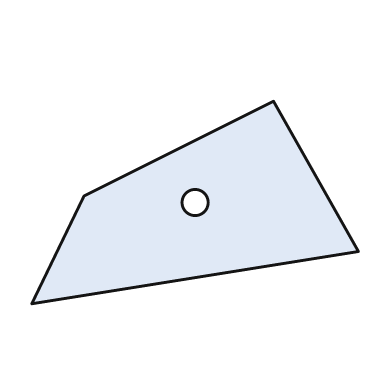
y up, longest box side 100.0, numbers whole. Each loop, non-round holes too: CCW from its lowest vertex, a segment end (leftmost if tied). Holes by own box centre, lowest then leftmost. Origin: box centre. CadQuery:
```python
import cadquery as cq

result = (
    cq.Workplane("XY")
    .moveTo(-50.0, -31.0)
    .lineTo(50.0, -15.0)
    .lineTo(24.0, 31.0)
    .lineTo(-34.0, 2.0)
    .close()
    .moveTo(0.0, 0.0)
    .circle(4.0)
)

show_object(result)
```